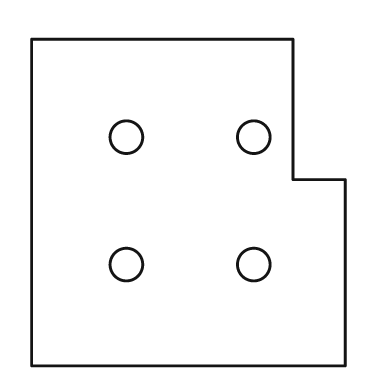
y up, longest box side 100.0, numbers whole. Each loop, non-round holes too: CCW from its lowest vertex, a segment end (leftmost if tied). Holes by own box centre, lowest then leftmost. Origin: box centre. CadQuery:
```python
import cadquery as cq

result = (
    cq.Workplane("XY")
    .moveTo(-48.0, -50.0)
    .lineTo(48.0, -50.0)
    .lineTo(48.0, 7.0)
    .lineTo(32.0, 7.0)
    .lineTo(32.0, 50.0)
    .lineTo(-48.0, 50.0)
    .close()
    .moveTo(-19.0, -19.0)
    .circle(5.0)
    .moveTo(20.0, -19.0)
    .circle(5.0)
    .moveTo(-19.0, 20.0)
    .circle(5.0)
    .moveTo(20.0, 20.0)
    .circle(5.0)
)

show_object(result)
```